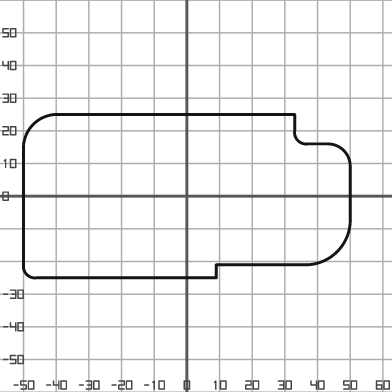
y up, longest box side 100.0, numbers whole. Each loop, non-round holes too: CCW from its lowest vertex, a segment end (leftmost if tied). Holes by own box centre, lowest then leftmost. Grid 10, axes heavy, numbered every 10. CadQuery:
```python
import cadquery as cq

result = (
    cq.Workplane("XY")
    .moveTo(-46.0, -25.0)
    .lineTo(9.0, -25.0)
    .lineTo(9.0, -21.0)
    .lineTo(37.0, -21.0)
    .threePointArc((46.0, -17.0), (50.0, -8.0))
    .lineTo(50.0, 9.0)
    .threePointArc((48.0, 14.0), (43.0, 16.0))
    .lineTo(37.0, 16.0)
    .threePointArc((34.0, 17.0), (33.0, 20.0))
    .lineTo(33.0, 25.0)
    .lineTo(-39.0, 25.0)
    .threePointArc((-47.0, 22.0), (-50.0, 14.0))
    .lineTo(-50.0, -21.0)
    .threePointArc((-49.0, -24.0), (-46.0, -25.0))
    .close()
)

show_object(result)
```